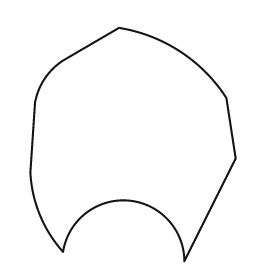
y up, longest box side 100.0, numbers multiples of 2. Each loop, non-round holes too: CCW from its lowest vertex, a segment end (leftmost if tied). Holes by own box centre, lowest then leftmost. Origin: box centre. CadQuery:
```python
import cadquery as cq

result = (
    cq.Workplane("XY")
    .moveTo(22.0, -50.0)
    .lineTo(44.0, -6.0)
    .lineTo(40.0, 20.0)
    .threePointArc((20.0, 40.0), (-6.0, 50.0))
    .lineTo(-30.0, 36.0)
    .threePointArc((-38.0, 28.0), (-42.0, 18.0))
    .lineTo(-44.0, -12.0)
    .threePointArc((-40.0, -30.0), (-30.0, -46.0))
    .threePointArc((-2.0, -24.0), (22.0, -50.0))
    .close()
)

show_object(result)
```